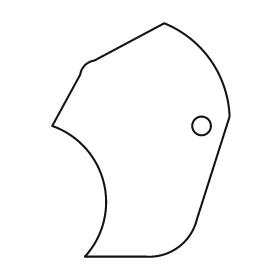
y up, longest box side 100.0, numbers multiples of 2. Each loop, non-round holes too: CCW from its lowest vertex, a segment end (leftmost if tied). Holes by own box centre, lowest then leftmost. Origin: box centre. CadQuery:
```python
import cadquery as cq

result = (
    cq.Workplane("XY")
    .moveTo(-24.0, -50.0)
    .lineTo(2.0, -50.0)
    .threePointArc((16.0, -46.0), (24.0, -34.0))
    .lineTo(38.0, 10.0)
    .threePointArc((30.0, 34.0), (10.0, 50.0))
    .lineTo(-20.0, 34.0)
    .threePointArc((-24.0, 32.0), (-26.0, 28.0))
    .lineTo(-38.0, 6.0)
    .threePointArc((-16.0, -18.0), (-24.0, -50.0))
    .close()
    .moveTo(26.0, 6.0)
    .circle(4.0)
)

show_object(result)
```